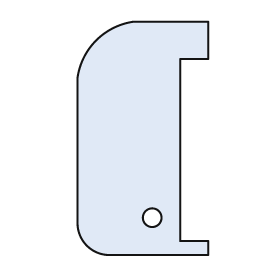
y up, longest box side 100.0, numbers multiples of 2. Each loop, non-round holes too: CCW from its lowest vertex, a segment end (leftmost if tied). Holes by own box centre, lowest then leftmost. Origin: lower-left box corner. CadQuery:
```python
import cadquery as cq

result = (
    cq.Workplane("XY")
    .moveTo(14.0, 0.0)
    .lineTo(56.0, 0.0)
    .lineTo(56.0, 6.0)
    .lineTo(44.0, 6.0)
    .lineTo(44.0, 84.0)
    .lineTo(56.0, 84.0)
    .lineTo(56.0, 100.0)
    .lineTo(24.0, 100.0)
    .threePointArc((8.0, 92.0), (0.0, 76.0))
    .lineTo(0.0, 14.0)
    .threePointArc((4.0, 4.0), (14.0, 0.0))
    .close()
    .moveTo(32.0, 16.0)
    .circle(4.0)
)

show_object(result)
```